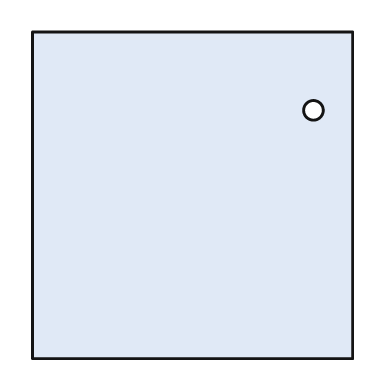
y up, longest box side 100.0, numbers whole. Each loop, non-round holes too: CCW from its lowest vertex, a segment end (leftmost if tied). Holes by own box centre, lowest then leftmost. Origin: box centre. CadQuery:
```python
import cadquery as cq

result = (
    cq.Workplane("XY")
    .moveTo(-49.0, -50.0)
    .lineTo(49.0, -50.0)
    .lineTo(49.0, 50.0)
    .lineTo(-49.0, 50.0)
    .close()
    .moveTo(37.0, 26.0)
    .circle(3.0)
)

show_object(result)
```